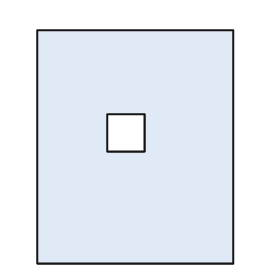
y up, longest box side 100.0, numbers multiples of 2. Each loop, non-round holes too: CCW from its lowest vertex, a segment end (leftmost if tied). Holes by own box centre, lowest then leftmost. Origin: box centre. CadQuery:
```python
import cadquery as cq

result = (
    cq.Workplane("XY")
    .moveTo(-42.0, -50.0)
    .lineTo(42.0, -50.0)
    .lineTo(42.0, 50.0)
    .lineTo(-42.0, 50.0)
    .close()
    .moveTo(-12.0, -2.0)
    .lineTo(4.0, -2.0)
    .lineTo(4.0, 14.0)
    .lineTo(-12.0, 14.0)
    .close()
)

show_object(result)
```